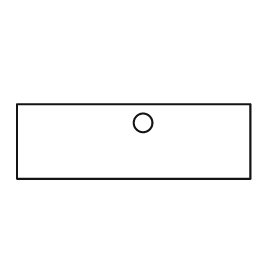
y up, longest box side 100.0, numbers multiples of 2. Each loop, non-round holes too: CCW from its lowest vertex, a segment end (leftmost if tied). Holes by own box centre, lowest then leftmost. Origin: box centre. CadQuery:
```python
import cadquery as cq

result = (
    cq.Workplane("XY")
    .moveTo(-50.0, -16.0)
    .lineTo(50.0, -16.0)
    .lineTo(50.0, 16.0)
    .lineTo(-50.0, 16.0)
    .close()
    .moveTo(4.0, 8.0)
    .circle(4.0)
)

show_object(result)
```